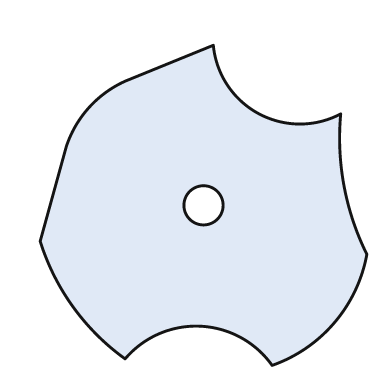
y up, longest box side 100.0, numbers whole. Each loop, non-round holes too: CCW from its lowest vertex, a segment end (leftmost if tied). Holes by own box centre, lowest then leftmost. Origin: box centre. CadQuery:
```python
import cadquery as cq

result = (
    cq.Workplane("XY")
    .moveTo(21.0, -49.0)
    .threePointArc((40.0, -36.0), (50.0, -15.0))
    .threePointArc((43.0, 6.0), (42.0, 28.0))
    .threePointArc((17.0, 28.0), (3.0, 49.0))
    .lineTo(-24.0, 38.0)
    .threePointArc((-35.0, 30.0), (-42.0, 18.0))
    .lineTo(-50.0, -11.0)
    .threePointArc((-40.0, -31.0), (-24.0, -47.0))
    .threePointArc((-1.0, -37.0), (21.0, -49.0))
    .close()
    .moveTo(0.0, 0.0)
    .circle(6.0)
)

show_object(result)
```